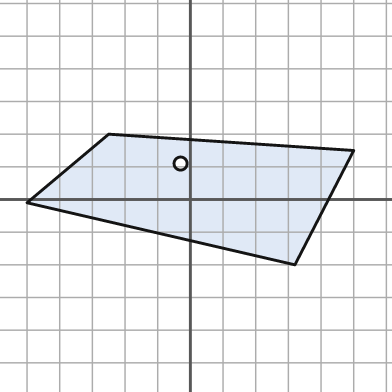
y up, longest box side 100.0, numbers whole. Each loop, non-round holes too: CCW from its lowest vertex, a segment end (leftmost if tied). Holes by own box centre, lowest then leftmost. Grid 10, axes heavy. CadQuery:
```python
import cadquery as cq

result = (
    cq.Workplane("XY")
    .moveTo(32.0, -20.0)
    .lineTo(50.0, 15.0)
    .lineTo(-25.0, 20.0)
    .lineTo(-50.0, -1.0)
    .close()
    .moveTo(-3.0, 11.0)
    .circle(2.0)
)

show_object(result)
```